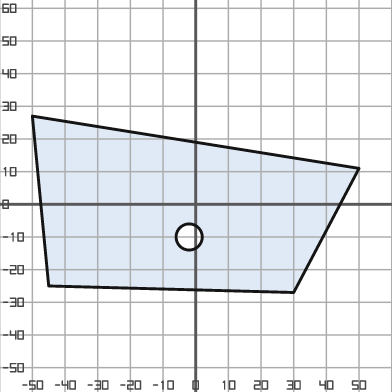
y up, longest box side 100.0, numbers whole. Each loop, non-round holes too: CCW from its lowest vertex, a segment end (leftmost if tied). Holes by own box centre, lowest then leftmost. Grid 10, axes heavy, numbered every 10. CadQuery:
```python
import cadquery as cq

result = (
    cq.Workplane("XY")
    .moveTo(30.0, -27.0)
    .lineTo(50.0, 11.0)
    .lineTo(-50.0, 27.0)
    .lineTo(-45.0, -25.0)
    .close()
    .moveTo(-2.0, -10.0)
    .circle(4.0)
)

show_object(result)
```